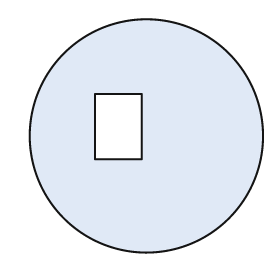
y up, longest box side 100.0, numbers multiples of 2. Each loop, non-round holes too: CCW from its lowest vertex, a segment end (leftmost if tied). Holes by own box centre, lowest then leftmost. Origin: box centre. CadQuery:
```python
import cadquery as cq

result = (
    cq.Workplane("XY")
    .moveTo(0.0, 0.0)
    .circle(50.0)
    .moveTo(-22.0, -10.0)
    .lineTo(-2.0, -10.0)
    .lineTo(-2.0, 18.0)
    .lineTo(-22.0, 18.0)
    .close()
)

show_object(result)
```